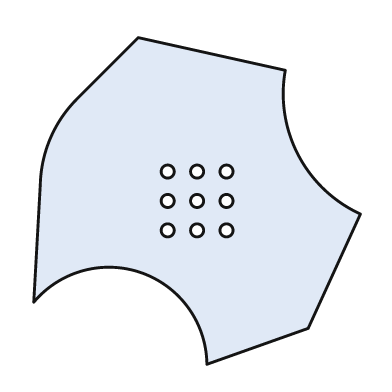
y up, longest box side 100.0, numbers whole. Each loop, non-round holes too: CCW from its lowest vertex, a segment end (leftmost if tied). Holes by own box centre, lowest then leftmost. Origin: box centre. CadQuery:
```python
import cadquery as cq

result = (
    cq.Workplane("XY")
    .moveTo(3.0, -50.0)
    .lineTo(34.0, -39.0)
    .lineTo(50.0, -4.0)
    .threePointArc((31.0, 14.0), (27.0, 40.0))
    .lineTo(-18.0, 50.0)
    .lineTo(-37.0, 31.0)
    .threePointArc((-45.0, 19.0), (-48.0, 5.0))
    .lineTo(-50.0, -31.0)
    .threePointArc((-17.0, -22.0), (3.0, -50.0))
    .close()
    .moveTo(-9.0, -9.0)
    .circle(2.0)
    .moveTo(0.0, -9.0)
    .circle(2.0)
    .moveTo(9.0, -9.0)
    .circle(2.0)
    .moveTo(-9.0, 0.0)
    .circle(2.0)
    .moveTo(0.0, 0.0)
    .circle(2.0)
    .moveTo(9.0, 0.0)
    .circle(2.0)
    .moveTo(-9.0, 9.0)
    .circle(2.0)
    .moveTo(0.0, 9.0)
    .circle(2.0)
    .moveTo(9.0, 9.0)
    .circle(2.0)
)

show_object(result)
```